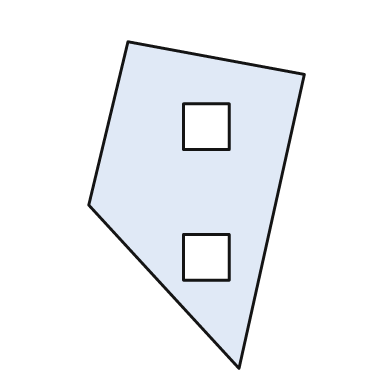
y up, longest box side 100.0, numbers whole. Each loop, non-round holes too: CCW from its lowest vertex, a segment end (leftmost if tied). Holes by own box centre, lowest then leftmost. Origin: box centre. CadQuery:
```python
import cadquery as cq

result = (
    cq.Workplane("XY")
    .moveTo(13.0, -50.0)
    .lineTo(33.0, 40.0)
    .lineTo(-21.0, 50.0)
    .lineTo(-33.0, 0.0)
    .close()
    .moveTo(-4.0, -23.0)
    .lineTo(10.0, -23.0)
    .lineTo(10.0, -9.0)
    .lineTo(-4.0, -9.0)
    .close()
    .moveTo(-4.0, 17.0)
    .lineTo(10.0, 17.0)
    .lineTo(10.0, 31.0)
    .lineTo(-4.0, 31.0)
    .close()
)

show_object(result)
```